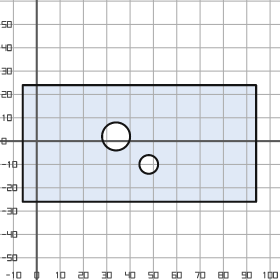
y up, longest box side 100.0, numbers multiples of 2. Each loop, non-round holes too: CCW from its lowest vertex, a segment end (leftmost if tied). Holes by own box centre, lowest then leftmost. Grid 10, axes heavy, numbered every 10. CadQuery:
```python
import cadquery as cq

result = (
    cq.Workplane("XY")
    .moveTo(-6.0, -26.0)
    .lineTo(94.0, -26.0)
    .lineTo(94.0, 24.0)
    .lineTo(-6.0, 24.0)
    .close()
    .moveTo(48.0, -10.0)
    .circle(4.0)
    .moveTo(34.0, 2.0)
    .circle(6.0)
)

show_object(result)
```